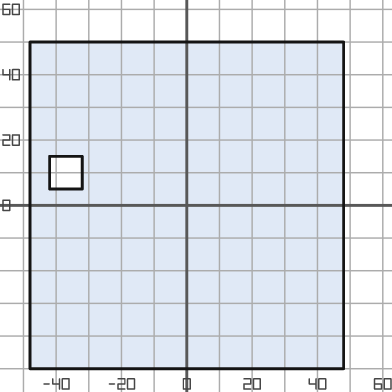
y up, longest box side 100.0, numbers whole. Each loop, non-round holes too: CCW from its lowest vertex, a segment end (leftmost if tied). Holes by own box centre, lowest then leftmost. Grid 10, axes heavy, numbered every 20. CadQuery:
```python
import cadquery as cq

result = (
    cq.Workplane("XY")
    .moveTo(-48.0, -50.0)
    .lineTo(48.0, -50.0)
    .lineTo(48.0, 50.0)
    .lineTo(-48.0, 50.0)
    .close()
    .moveTo(-42.0, 5.0)
    .lineTo(-32.0, 5.0)
    .lineTo(-32.0, 15.0)
    .lineTo(-42.0, 15.0)
    .close()
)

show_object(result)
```